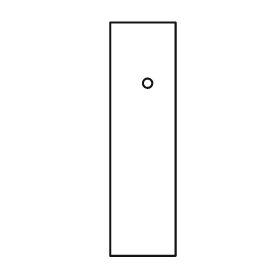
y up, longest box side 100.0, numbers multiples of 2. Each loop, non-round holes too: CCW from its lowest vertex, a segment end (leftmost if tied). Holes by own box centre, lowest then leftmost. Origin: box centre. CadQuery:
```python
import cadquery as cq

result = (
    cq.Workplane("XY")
    .moveTo(-14.0, -50.0)
    .lineTo(14.0, -50.0)
    .lineTo(14.0, 50.0)
    .lineTo(-14.0, 50.0)
    .close()
    .moveTo(2.0, 24.0)
    .circle(2.0)
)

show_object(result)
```